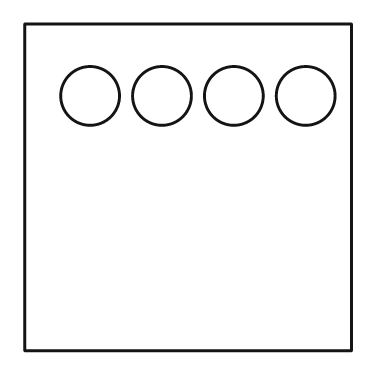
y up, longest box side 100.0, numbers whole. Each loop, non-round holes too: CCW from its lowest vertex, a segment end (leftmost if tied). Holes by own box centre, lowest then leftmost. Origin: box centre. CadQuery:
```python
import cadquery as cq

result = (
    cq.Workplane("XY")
    .moveTo(-50.0, -50.0)
    .lineTo(50.0, -50.0)
    .lineTo(50.0, 50.0)
    .lineTo(-50.0, 50.0)
    .close()
    .moveTo(-30.0, 28.0)
    .circle(9.0)
    .moveTo(-8.0, 28.0)
    .circle(9.0)
    .moveTo(14.0, 28.0)
    .circle(9.0)
    .moveTo(36.0, 28.0)
    .circle(9.0)
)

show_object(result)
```